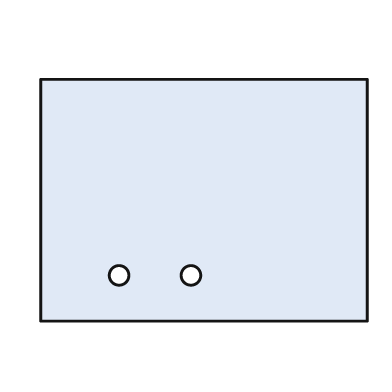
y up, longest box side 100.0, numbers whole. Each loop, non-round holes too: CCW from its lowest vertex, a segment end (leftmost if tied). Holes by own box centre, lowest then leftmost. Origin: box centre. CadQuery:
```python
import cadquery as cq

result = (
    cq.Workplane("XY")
    .moveTo(-50.0, -37.0)
    .lineTo(50.0, -37.0)
    .lineTo(50.0, 37.0)
    .lineTo(-50.0, 37.0)
    .close()
    .moveTo(-26.0, -23.0)
    .circle(3.0)
    .moveTo(-4.0, -23.0)
    .circle(3.0)
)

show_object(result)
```